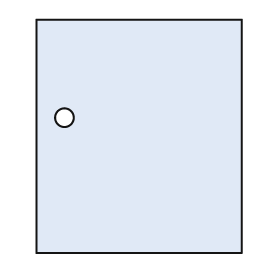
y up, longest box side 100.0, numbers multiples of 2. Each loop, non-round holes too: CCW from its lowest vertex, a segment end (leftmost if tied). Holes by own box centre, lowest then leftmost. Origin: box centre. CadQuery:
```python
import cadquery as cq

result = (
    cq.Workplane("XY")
    .moveTo(-44.0, -50.0)
    .lineTo(44.0, -50.0)
    .lineTo(44.0, 50.0)
    .lineTo(-44.0, 50.0)
    .close()
    .moveTo(-32.0, 8.0)
    .circle(4.0)
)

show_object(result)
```